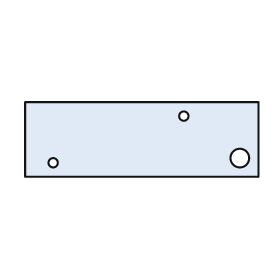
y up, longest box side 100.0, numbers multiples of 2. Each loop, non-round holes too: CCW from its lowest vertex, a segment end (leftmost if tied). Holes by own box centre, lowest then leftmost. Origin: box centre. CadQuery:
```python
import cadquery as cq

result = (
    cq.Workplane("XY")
    .moveTo(-50.0, -16.0)
    .lineTo(50.0, -16.0)
    .lineTo(50.0, 16.0)
    .lineTo(-50.0, 16.0)
    .close()
    .moveTo(-38.0, -10.0)
    .circle(2.0)
    .moveTo(42.0, -8.0)
    .circle(4.0)
    .moveTo(18.0, 10.0)
    .circle(2.0)
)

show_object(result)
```